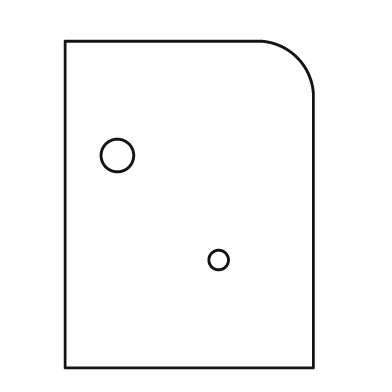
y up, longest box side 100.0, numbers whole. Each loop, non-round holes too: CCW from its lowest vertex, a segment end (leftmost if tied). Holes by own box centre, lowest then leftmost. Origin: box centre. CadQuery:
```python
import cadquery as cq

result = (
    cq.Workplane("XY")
    .moveTo(-38.0, -50.0)
    .lineTo(38.0, -50.0)
    .lineTo(38.0, 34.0)
    .threePointArc((33.0, 45.0), (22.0, 50.0))
    .lineTo(-38.0, 50.0)
    .close()
    .moveTo(9.0, -17.0)
    .circle(3.0)
    .moveTo(-22.0, 15.0)
    .circle(5.0)
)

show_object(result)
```